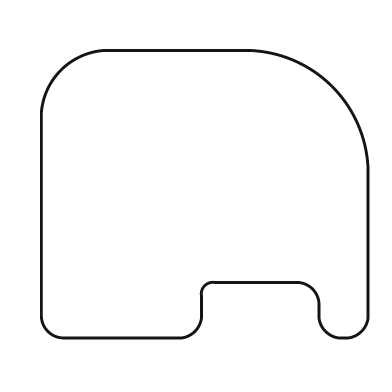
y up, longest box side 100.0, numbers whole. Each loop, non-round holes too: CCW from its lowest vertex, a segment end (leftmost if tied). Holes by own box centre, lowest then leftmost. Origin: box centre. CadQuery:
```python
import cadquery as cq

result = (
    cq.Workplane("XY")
    .moveTo(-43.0, -44.0)
    .lineTo(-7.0, -44.0)
    .threePointArc((-3.0, -42.0), (-1.0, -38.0))
    .lineTo(-1.0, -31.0)
    .threePointArc((0.0, -28.0), (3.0, -27.0))
    .lineTo(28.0, -27.0)
    .threePointArc((33.0, -29.0), (35.0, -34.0))
    .lineTo(35.0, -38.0)
    .threePointArc((37.0, -42.0), (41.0, -44.0))
    .lineTo(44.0, -44.0)
    .threePointArc((48.0, -42.0), (50.0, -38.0))
    .lineTo(50.0, 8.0)
    .threePointArc((39.0, 33.0), (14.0, 44.0))
    .lineTo(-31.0, 44.0)
    .threePointArc((-44.0, 38.0), (-50.0, 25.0))
    .lineTo(-50.0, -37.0)
    .threePointArc((-48.0, -42.0), (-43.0, -44.0))
    .close()
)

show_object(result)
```